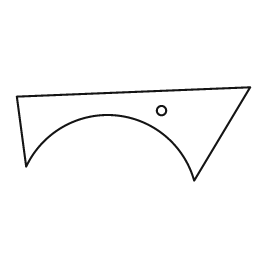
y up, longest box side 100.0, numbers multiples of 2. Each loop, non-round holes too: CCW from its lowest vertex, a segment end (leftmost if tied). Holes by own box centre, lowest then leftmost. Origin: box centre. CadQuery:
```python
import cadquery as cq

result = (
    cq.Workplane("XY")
    .moveTo(26.0, -20.0)
    .lineTo(50.0, 20.0)
    .lineTo(-50.0, 16.0)
    .lineTo(-46.0, -14.0)
    .threePointArc((-8.0, 8.0), (26.0, -20.0))
    .close()
    .moveTo(12.0, 10.0)
    .circle(2.0)
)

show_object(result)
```